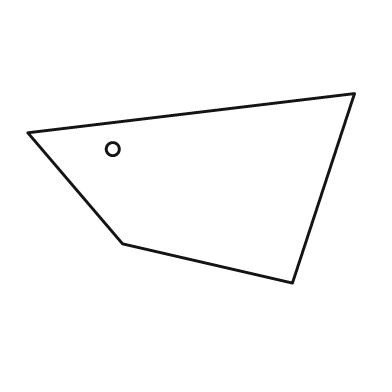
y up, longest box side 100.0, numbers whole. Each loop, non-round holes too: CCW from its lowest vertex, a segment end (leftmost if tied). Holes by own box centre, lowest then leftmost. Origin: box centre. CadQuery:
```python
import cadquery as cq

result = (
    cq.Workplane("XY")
    .moveTo(31.0, -29.0)
    .lineTo(50.0, 29.0)
    .lineTo(-50.0, 17.0)
    .lineTo(-21.0, -17.0)
    .close()
    .moveTo(-24.0, 12.0)
    .circle(2.0)
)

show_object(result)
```